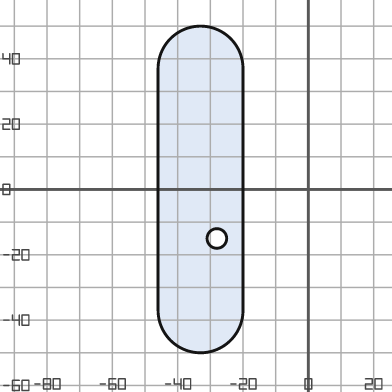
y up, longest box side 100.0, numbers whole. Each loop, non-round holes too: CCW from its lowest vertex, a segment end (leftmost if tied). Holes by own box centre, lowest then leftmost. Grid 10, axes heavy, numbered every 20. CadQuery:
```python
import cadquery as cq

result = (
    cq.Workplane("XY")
    .moveTo(-46.0, -37.0)
    .threePointArc((-33.0, -50.0), (-20.0, -37.0))
    .lineTo(-20.0, 37.0)
    .threePointArc((-33.0, 50.0), (-46.0, 37.0))
    .close()
    .moveTo(-28.0, -15.0)
    .circle(3.0)
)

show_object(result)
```